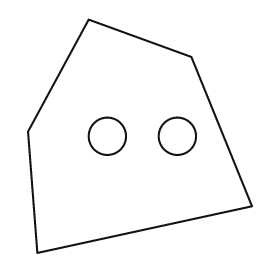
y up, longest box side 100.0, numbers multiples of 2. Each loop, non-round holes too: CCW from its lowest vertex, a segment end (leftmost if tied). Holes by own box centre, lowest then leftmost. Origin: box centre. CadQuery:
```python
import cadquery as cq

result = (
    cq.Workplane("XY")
    .moveTo(-44.0, -50.0)
    .lineTo(48.0, -30.0)
    .lineTo(22.0, 34.0)
    .lineTo(-22.0, 50.0)
    .lineTo(-48.0, 2.0)
    .close()
    .moveTo(-14.0, 0.0)
    .circle(8.0)
    .moveTo(16.0, 0.0)
    .circle(8.0)
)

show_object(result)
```